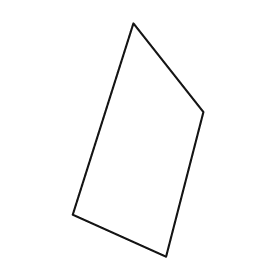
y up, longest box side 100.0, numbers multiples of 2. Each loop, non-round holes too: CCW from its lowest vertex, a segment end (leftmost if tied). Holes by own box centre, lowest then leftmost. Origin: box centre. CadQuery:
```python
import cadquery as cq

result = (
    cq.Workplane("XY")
    .moveTo(12.0, -50.0)
    .lineTo(28.0, 12.0)
    .lineTo(-2.0, 50.0)
    .lineTo(-28.0, -32.0)
    .close()
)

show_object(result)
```